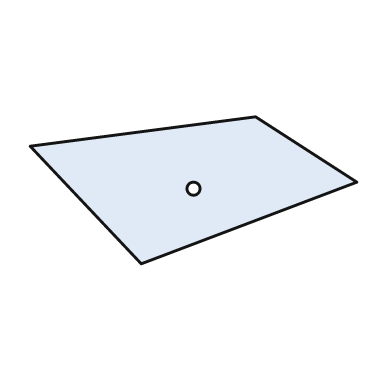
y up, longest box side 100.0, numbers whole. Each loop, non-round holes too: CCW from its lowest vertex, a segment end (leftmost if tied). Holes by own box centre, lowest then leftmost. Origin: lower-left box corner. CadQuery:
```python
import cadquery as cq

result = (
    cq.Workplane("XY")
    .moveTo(34.0, 0.0)
    .lineTo(100.0, 25.0)
    .lineTo(69.0, 45.0)
    .lineTo(0.0, 36.0)
    .close()
    .moveTo(50.0, 23.0)
    .circle(2.0)
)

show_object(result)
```